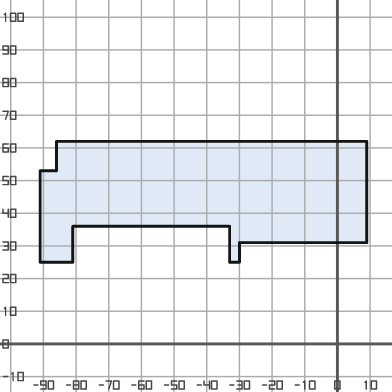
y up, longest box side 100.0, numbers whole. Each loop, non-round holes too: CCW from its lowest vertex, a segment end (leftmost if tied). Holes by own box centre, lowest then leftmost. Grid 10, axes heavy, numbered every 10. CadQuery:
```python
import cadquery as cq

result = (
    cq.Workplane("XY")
    .moveTo(-91.0, 25.0)
    .lineTo(-81.0, 25.0)
    .lineTo(-81.0, 36.0)
    .lineTo(-33.0, 36.0)
    .lineTo(-33.0, 25.0)
    .lineTo(-30.0, 25.0)
    .lineTo(-30.0, 31.0)
    .lineTo(9.0, 31.0)
    .lineTo(9.0, 62.0)
    .lineTo(-86.0, 62.0)
    .lineTo(-86.0, 53.0)
    .lineTo(-91.0, 53.0)
    .close()
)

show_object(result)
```